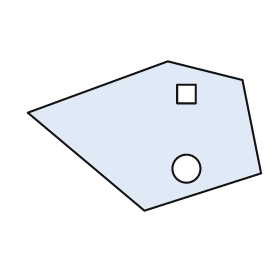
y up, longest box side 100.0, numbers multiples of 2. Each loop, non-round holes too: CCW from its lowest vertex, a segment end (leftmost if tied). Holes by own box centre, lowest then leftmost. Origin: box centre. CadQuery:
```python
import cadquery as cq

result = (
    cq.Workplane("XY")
    .moveTo(0.0, -32.0)
    .lineTo(50.0, -16.0)
    .lineTo(42.0, 24.0)
    .lineTo(10.0, 32.0)
    .lineTo(-50.0, 10.0)
    .close()
    .moveTo(18.0, -14.0)
    .circle(6.0)
    .moveTo(14.0, 14.0)
    .lineTo(22.0, 14.0)
    .lineTo(22.0, 22.0)
    .lineTo(14.0, 22.0)
    .close()
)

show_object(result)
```